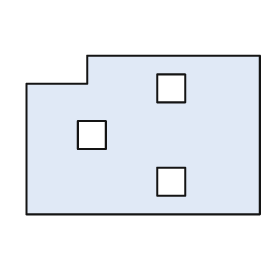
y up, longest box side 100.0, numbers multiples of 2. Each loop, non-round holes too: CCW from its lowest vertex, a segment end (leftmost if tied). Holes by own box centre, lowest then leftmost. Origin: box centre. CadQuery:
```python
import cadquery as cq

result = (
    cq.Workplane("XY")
    .moveTo(-50.0, -34.0)
    .lineTo(50.0, -34.0)
    .lineTo(50.0, 34.0)
    .lineTo(-24.0, 34.0)
    .lineTo(-24.0, 22.0)
    .lineTo(-50.0, 22.0)
    .close()
    .moveTo(6.0, -26.0)
    .lineTo(18.0, -26.0)
    .lineTo(18.0, -14.0)
    .lineTo(6.0, -14.0)
    .close()
    .moveTo(-28.0, -6.0)
    .lineTo(-16.0, -6.0)
    .lineTo(-16.0, 6.0)
    .lineTo(-28.0, 6.0)
    .close()
    .moveTo(6.0, 14.0)
    .lineTo(18.0, 14.0)
    .lineTo(18.0, 26.0)
    .lineTo(6.0, 26.0)
    .close()
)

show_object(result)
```